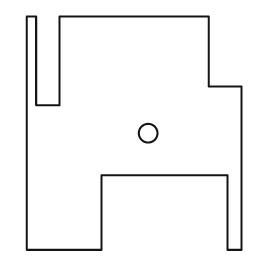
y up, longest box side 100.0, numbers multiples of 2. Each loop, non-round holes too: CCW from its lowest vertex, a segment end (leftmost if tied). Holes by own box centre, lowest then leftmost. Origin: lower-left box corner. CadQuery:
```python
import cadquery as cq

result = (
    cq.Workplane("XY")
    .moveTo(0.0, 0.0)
    .lineTo(32.0, 0.0)
    .lineTo(32.0, 32.0)
    .lineTo(86.0, 32.0)
    .lineTo(86.0, 0.0)
    .lineTo(92.0, 0.0)
    .lineTo(92.0, 70.0)
    .lineTo(78.0, 70.0)
    .lineTo(78.0, 100.0)
    .lineTo(14.0, 100.0)
    .lineTo(14.0, 62.0)
    .lineTo(4.0, 62.0)
    .lineTo(4.0, 100.0)
    .lineTo(0.0, 100.0)
    .close()
    .moveTo(52.0, 50.0)
    .circle(4.0)
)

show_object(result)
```